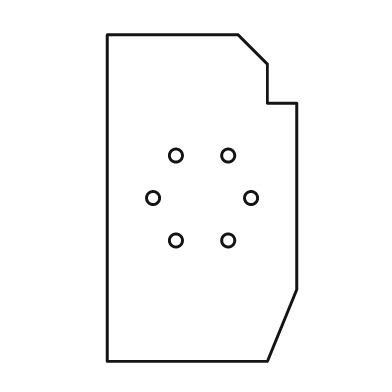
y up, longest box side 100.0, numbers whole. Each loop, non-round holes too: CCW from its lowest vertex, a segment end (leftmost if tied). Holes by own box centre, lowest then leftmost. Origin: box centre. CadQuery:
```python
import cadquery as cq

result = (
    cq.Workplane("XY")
    .moveTo(-29.0, -50.0)
    .lineTo(20.0, -50.0)
    .lineTo(29.0, -28.0)
    .lineTo(29.0, 29.0)
    .lineTo(20.0, 29.0)
    .lineTo(20.0, 41.0)
    .lineTo(11.0, 50.0)
    .lineTo(-29.0, 50.0)
    .close()
    .moveTo(-8.0, -13.0)
    .circle(2.0)
    .moveTo(8.0, -13.0)
    .circle(2.0)
    .moveTo(-15.0, 0.0)
    .circle(2.0)
    .moveTo(15.0, 0.0)
    .circle(2.0)
    .moveTo(-8.0, 13.0)
    .circle(2.0)
    .moveTo(8.0, 13.0)
    .circle(2.0)
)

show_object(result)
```